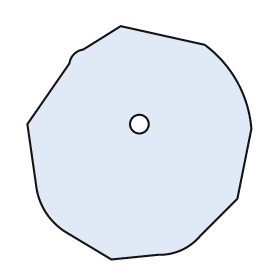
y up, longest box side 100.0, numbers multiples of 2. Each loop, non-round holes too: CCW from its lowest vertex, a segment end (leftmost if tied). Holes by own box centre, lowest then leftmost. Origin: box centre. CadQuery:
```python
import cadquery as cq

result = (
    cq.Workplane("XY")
    .moveTo(-12.0, -50.0)
    .lineTo(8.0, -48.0)
    .threePointArc((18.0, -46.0), (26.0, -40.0))
    .lineTo(42.0, -24.0)
    .lineTo(48.0, 6.0)
    .threePointArc((42.0, 26.0), (28.0, 42.0))
    .lineTo(-8.0, 50.0)
    .lineTo(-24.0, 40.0)
    .threePointArc((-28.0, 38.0), (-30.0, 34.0))
    .lineTo(-48.0, 8.0)
    .lineTo(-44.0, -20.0)
    .threePointArc((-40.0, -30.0), (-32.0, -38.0))
    .close()
    .moveTo(0.0, 8.0)
    .circle(4.0)
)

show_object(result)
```